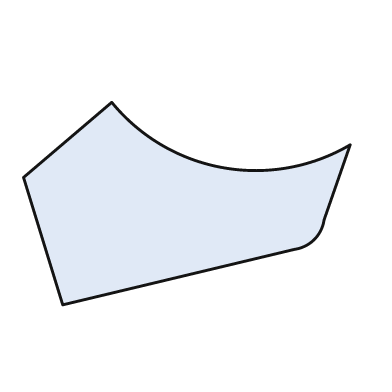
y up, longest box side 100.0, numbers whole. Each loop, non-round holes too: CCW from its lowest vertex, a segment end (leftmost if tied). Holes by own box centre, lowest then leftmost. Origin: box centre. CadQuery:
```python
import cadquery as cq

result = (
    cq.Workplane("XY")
    .moveTo(-38.0, -31.0)
    .lineTo(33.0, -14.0)
    .threePointArc((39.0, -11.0), (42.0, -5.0))
    .lineTo(50.0, 18.0)
    .threePointArc((11.0, 11.0), (-23.0, 31.0))
    .lineTo(-50.0, 8.0)
    .close()
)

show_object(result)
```